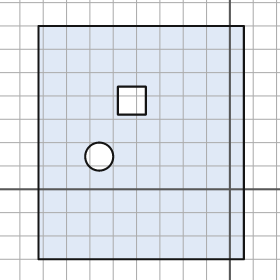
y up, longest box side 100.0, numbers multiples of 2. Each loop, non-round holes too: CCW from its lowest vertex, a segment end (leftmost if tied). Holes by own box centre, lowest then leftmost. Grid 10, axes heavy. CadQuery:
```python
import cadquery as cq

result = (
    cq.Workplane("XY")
    .moveTo(-82.0, -30.0)
    .lineTo(6.0, -30.0)
    .lineTo(6.0, 70.0)
    .lineTo(-82.0, 70.0)
    .close()
    .moveTo(-56.0, 14.0)
    .circle(6.0)
    .moveTo(-48.0, 32.0)
    .lineTo(-36.0, 32.0)
    .lineTo(-36.0, 44.0)
    .lineTo(-48.0, 44.0)
    .close()
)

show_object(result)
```